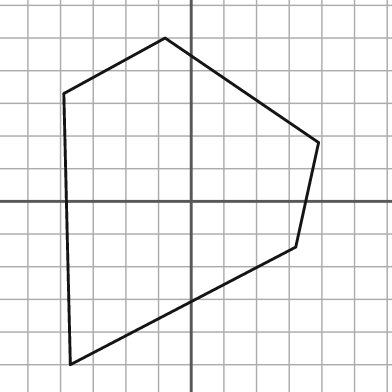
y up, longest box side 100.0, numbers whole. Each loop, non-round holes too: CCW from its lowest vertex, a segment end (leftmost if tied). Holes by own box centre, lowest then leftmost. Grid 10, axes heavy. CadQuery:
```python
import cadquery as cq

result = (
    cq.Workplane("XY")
    .moveTo(-37.0, -50.0)
    .lineTo(32.0, -14.0)
    .lineTo(39.0, 18.0)
    .lineTo(-8.0, 50.0)
    .lineTo(-39.0, 33.0)
    .close()
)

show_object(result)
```